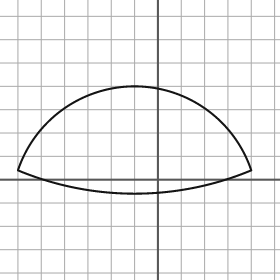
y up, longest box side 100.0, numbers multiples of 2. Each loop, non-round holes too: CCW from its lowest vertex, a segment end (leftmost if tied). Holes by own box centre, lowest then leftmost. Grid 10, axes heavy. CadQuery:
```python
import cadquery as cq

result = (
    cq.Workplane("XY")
    .moveTo(-60.0, 4.0)
    .threePointArc((-10.0, -6.0), (40.0, 4.0))
    .threePointArc((-10.0, 40.0), (-60.0, 4.0))
    .close()
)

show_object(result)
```